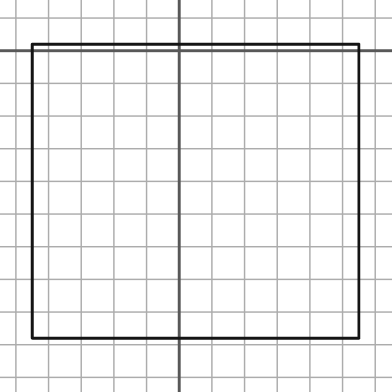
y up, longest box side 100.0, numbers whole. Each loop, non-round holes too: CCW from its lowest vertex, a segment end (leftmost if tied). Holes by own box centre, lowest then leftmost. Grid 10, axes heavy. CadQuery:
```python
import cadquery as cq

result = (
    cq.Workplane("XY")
    .moveTo(-45.0, -88.0)
    .lineTo(55.0, -88.0)
    .lineTo(55.0, 2.0)
    .lineTo(-45.0, 2.0)
    .close()
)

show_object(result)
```